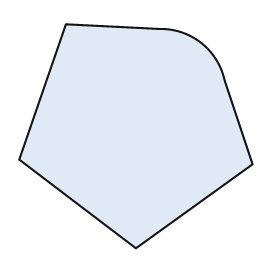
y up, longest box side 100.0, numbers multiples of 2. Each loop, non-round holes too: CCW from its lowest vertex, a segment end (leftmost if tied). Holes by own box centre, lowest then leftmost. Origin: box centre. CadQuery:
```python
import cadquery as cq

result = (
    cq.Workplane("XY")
    .moveTo(0.0, -48.0)
    .lineTo(50.0, -12.0)
    .lineTo(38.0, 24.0)
    .threePointArc((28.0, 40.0), (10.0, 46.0))
    .lineTo(-30.0, 48.0)
    .lineTo(-50.0, -10.0)
    .close()
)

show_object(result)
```